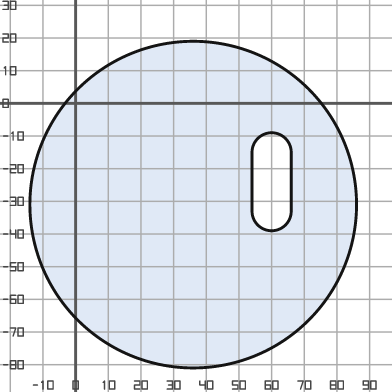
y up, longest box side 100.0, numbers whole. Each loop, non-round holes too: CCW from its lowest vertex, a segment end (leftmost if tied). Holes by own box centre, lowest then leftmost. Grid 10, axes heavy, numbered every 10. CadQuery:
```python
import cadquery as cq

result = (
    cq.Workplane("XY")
    .moveTo(36.0, -31.0)
    .circle(50.0)
    .moveTo(54.0, -33.0)
    .threePointArc((60.0, -39.0), (66.0, -33.0))
    .lineTo(66.0, -15.0)
    .threePointArc((60.0, -9.0), (54.0, -15.0))
    .close()
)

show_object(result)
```